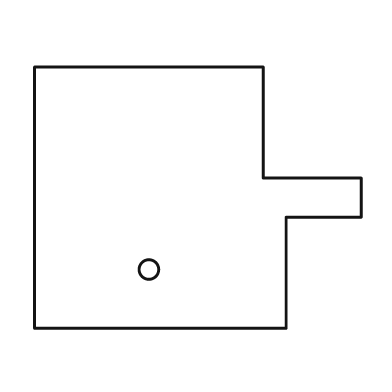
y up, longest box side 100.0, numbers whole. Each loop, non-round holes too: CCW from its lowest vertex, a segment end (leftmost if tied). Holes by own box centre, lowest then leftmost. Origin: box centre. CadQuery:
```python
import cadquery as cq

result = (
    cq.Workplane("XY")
    .moveTo(-50.0, -40.0)
    .lineTo(27.0, -40.0)
    .lineTo(27.0, -6.0)
    .lineTo(50.0, -6.0)
    .lineTo(50.0, 6.0)
    .lineTo(20.0, 6.0)
    .lineTo(20.0, 40.0)
    .lineTo(-50.0, 40.0)
    .close()
    .moveTo(-15.0, -22.0)
    .circle(3.0)
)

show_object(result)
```